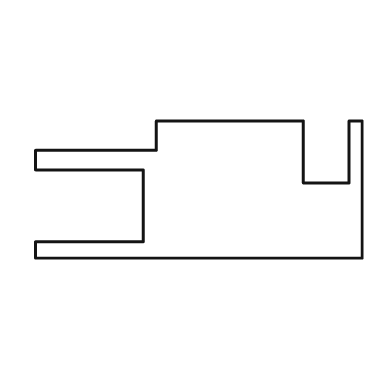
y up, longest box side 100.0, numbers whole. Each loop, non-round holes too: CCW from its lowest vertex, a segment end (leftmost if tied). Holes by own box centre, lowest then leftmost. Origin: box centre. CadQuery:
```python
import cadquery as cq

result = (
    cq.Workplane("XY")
    .moveTo(-50.0, -21.0)
    .lineTo(50.0, -21.0)
    .lineTo(50.0, 21.0)
    .lineTo(46.0, 21.0)
    .lineTo(46.0, 2.0)
    .lineTo(32.0, 2.0)
    .lineTo(32.0, 21.0)
    .lineTo(-13.0, 21.0)
    .lineTo(-13.0, 12.0)
    .lineTo(-50.0, 12.0)
    .lineTo(-50.0, 6.0)
    .lineTo(-17.0, 6.0)
    .lineTo(-17.0, -16.0)
    .lineTo(-50.0, -16.0)
    .close()
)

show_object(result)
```